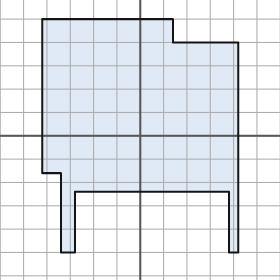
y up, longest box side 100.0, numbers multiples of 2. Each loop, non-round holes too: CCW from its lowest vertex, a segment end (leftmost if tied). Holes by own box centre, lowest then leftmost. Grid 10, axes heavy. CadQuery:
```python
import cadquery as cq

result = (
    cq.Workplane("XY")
    .moveTo(-34.0, -50.0)
    .lineTo(-28.0, -50.0)
    .lineTo(-28.0, -24.0)
    .lineTo(38.0, -24.0)
    .lineTo(38.0, -50.0)
    .lineTo(42.0, -50.0)
    .lineTo(42.0, 40.0)
    .lineTo(14.0, 40.0)
    .lineTo(14.0, 50.0)
    .lineTo(-42.0, 50.0)
    .lineTo(-42.0, -16.0)
    .lineTo(-34.0, -16.0)
    .close()
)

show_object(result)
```